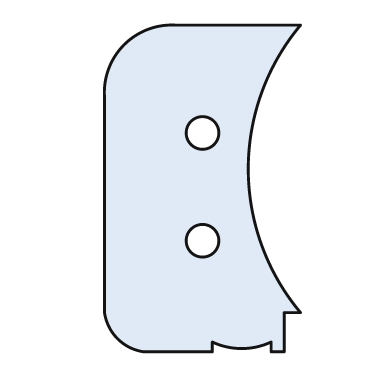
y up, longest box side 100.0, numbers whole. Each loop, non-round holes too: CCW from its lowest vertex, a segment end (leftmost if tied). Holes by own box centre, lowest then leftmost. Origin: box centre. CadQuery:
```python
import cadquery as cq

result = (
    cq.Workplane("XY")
    .moveTo(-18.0, -50.0)
    .lineTo(3.0, -50.0)
    .lineTo(3.0, -47.0)
    .threePointArc((12.0, -49.0), (21.0, -47.0))
    .lineTo(21.0, -50.0)
    .lineTo(25.0, -50.0)
    .lineTo(25.0, -38.0)
    .lineTo(30.0, -38.0)
    .threePointArc((14.0, 6.0), (30.0, 50.0))
    .lineTo(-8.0, 50.0)
    .threePointArc((-24.0, 44.0), (-30.0, 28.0))
    .lineTo(-30.0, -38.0)
    .threePointArc((-26.0, -46.0), (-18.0, -50.0))
    .close()
    .moveTo(0.0, -16.0)
    .circle(5.0)
    .moveTo(0.0, 17.0)
    .circle(5.0)
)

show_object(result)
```